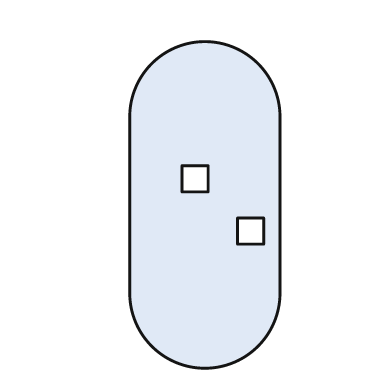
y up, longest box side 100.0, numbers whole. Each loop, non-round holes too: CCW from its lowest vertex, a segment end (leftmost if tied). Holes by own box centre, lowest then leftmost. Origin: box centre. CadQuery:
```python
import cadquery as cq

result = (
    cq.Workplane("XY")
    .moveTo(-23.0, -27.0)
    .threePointArc((0.0, -50.0), (23.0, -27.0))
    .lineTo(23.0, 27.0)
    .threePointArc((0.0, 50.0), (-23.0, 27.0))
    .close()
    .moveTo(10.0, -12.0)
    .lineTo(18.0, -12.0)
    .lineTo(18.0, -4.0)
    .lineTo(10.0, -4.0)
    .close()
    .moveTo(-7.0, 4.0)
    .lineTo(1.0, 4.0)
    .lineTo(1.0, 12.0)
    .lineTo(-7.0, 12.0)
    .close()
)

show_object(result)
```